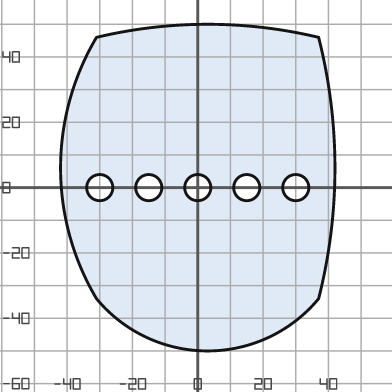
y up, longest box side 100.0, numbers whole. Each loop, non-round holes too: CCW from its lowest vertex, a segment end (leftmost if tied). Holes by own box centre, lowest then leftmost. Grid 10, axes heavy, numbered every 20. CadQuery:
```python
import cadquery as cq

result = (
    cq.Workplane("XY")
    .moveTo(-31.0, -34.0)
    .threePointArc((3.0, -50.0), (37.0, -34.0))
    .threePointArc((42.0, 6.0), (37.0, 46.0))
    .threePointArc((3.0, 50.0), (-31.0, 46.0))
    .threePointArc((-42.0, 6.0), (-31.0, -34.0))
    .close()
    .moveTo(-30.0, 0.0)
    .circle(4.0)
    .moveTo(-15.0, 0.0)
    .circle(4.0)
    .moveTo(0.0, 0.0)
    .circle(4.0)
    .moveTo(15.0, 0.0)
    .circle(4.0)
    .moveTo(30.0, 0.0)
    .circle(4.0)
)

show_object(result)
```